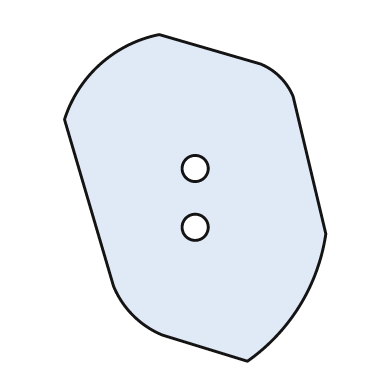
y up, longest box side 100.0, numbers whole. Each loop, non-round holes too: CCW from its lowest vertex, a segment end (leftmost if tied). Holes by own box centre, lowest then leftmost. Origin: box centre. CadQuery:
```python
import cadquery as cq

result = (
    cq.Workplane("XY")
    .moveTo(16.0, -50.0)
    .threePointArc((32.0, -33.0), (40.0, -11.0))
    .lineTo(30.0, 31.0)
    .threePointArc((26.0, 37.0), (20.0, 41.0))
    .lineTo(-11.0, 50.0)
    .threePointArc((-29.0, 41.0), (-40.0, 24.0))
    .lineTo(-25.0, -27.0)
    .threePointArc((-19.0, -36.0), (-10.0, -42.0))
    .close()
    .moveTo(0.0, -9.0)
    .circle(4.0)
    .moveTo(0.0, 9.0)
    .circle(4.0)
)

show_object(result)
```